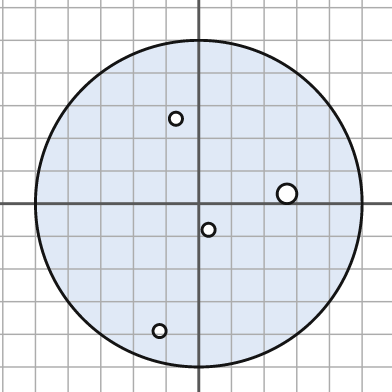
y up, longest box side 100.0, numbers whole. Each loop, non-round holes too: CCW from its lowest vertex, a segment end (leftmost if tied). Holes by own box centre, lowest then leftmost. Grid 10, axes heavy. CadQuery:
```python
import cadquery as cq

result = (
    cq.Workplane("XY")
    .moveTo(0.0, 0.0)
    .circle(50.0)
    .moveTo(-12.0, -39.0)
    .circle(2.0)
    .moveTo(3.0, -8.0)
    .circle(2.0)
    .moveTo(27.0, 3.0)
    .circle(3.0)
    .moveTo(-7.0, 26.0)
    .circle(2.0)
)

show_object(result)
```